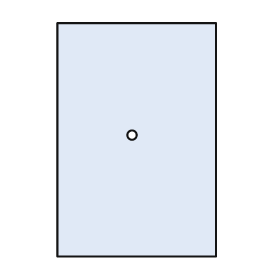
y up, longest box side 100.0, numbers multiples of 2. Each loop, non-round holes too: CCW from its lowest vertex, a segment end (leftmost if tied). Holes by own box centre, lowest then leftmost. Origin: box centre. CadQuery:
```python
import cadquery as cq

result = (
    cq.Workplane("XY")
    .moveTo(-34.0, -50.0)
    .lineTo(34.0, -50.0)
    .lineTo(34.0, 50.0)
    .lineTo(-34.0, 50.0)
    .close()
    .moveTo(-2.0, 2.0)
    .circle(2.0)
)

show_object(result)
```